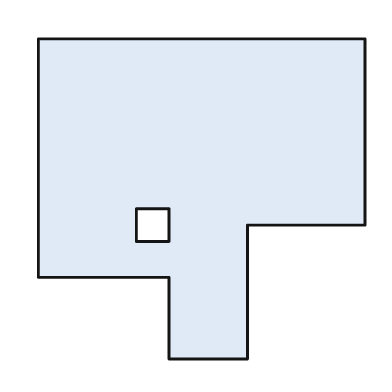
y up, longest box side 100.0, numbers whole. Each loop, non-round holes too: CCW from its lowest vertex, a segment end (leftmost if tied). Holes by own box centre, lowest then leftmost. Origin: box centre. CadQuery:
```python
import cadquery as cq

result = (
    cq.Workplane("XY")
    .moveTo(-10.0, -49.0)
    .lineTo(14.0, -49.0)
    .lineTo(14.0, -8.0)
    .lineTo(50.0, -8.0)
    .lineTo(50.0, 49.0)
    .lineTo(-50.0, 49.0)
    .lineTo(-50.0, -24.0)
    .lineTo(-10.0, -24.0)
    .close()
    .moveTo(-20.0, -13.0)
    .lineTo(-10.0, -13.0)
    .lineTo(-10.0, -3.0)
    .lineTo(-20.0, -3.0)
    .close()
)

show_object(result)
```